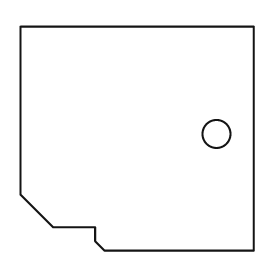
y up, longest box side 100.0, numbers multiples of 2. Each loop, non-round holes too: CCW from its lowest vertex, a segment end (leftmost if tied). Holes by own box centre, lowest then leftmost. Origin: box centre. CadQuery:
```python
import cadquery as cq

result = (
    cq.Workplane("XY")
    .moveTo(-14.0, -48.0)
    .lineTo(50.0, -48.0)
    .lineTo(50.0, 48.0)
    .lineTo(-50.0, 48.0)
    .lineTo(-50.0, -24.0)
    .lineTo(-36.0, -38.0)
    .lineTo(-18.0, -38.0)
    .lineTo(-18.0, -44.0)
    .close()
    .moveTo(34.0, 2.0)
    .circle(6.0)
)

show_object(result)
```